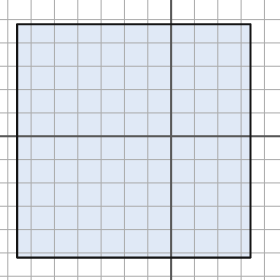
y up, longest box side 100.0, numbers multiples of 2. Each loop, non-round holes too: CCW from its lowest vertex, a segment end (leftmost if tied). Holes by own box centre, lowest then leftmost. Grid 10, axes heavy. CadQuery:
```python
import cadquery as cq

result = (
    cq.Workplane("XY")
    .moveTo(-66.0, -52.0)
    .lineTo(34.0, -52.0)
    .lineTo(34.0, 48.0)
    .lineTo(-66.0, 48.0)
    .close()
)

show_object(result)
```